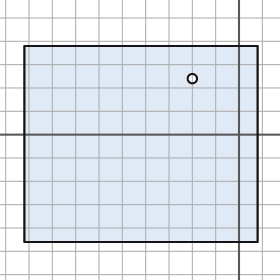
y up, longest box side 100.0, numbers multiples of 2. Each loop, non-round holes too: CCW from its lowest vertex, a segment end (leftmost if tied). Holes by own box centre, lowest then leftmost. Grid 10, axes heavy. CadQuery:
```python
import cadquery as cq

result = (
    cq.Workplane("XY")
    .moveTo(-92.0, -46.0)
    .lineTo(8.0, -46.0)
    .lineTo(8.0, 38.0)
    .lineTo(-92.0, 38.0)
    .close()
    .moveTo(-20.0, 24.0)
    .circle(2.0)
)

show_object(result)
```